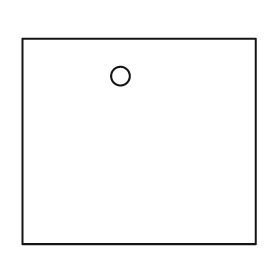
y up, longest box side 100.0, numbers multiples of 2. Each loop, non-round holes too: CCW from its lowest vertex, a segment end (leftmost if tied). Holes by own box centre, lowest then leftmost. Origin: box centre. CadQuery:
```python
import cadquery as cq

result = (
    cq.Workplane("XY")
    .moveTo(-50.0, -44.0)
    .lineTo(50.0, -44.0)
    .lineTo(50.0, 44.0)
    .lineTo(-50.0, 44.0)
    .close()
    .moveTo(-8.0, 28.0)
    .circle(4.0)
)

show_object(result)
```